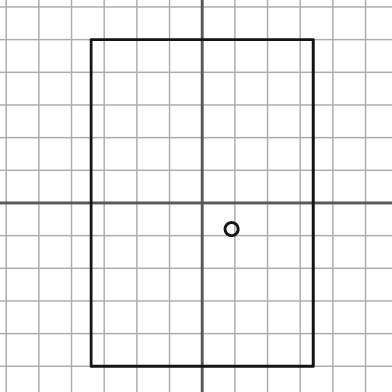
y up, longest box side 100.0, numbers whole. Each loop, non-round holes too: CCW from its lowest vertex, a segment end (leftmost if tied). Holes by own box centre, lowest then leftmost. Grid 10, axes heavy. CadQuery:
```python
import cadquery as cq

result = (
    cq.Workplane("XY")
    .moveTo(-34.0, -50.0)
    .lineTo(34.0, -50.0)
    .lineTo(34.0, 50.0)
    .lineTo(-34.0, 50.0)
    .close()
    .moveTo(9.0, -8.0)
    .circle(2.0)
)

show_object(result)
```